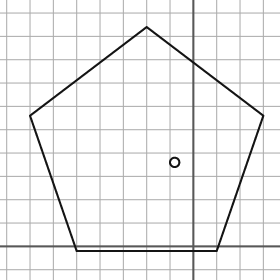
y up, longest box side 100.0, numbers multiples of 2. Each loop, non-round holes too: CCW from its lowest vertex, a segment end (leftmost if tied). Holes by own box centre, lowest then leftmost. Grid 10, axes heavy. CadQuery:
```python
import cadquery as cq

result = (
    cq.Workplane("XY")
    .moveTo(-50.0, -2.0)
    .lineTo(10.0, -2.0)
    .lineTo(30.0, 56.0)
    .lineTo(-20.0, 94.0)
    .lineTo(-70.0, 56.0)
    .close()
    .moveTo(-8.0, 36.0)
    .circle(2.0)
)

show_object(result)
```